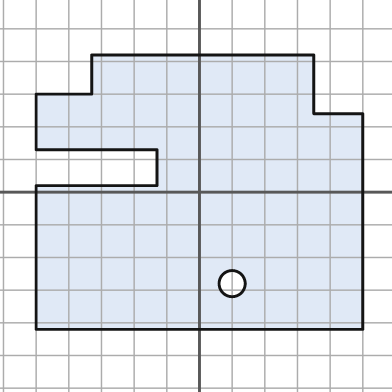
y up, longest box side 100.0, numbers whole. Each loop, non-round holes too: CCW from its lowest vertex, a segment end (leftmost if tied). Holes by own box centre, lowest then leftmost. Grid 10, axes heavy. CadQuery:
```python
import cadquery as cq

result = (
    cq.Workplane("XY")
    .moveTo(-50.0, -42.0)
    .lineTo(50.0, -42.0)
    .lineTo(50.0, 24.0)
    .lineTo(35.0, 24.0)
    .lineTo(35.0, 42.0)
    .lineTo(-33.0, 42.0)
    .lineTo(-33.0, 30.0)
    .lineTo(-50.0, 30.0)
    .lineTo(-50.0, 13.0)
    .lineTo(-13.0, 13.0)
    .lineTo(-13.0, 2.0)
    .lineTo(-50.0, 2.0)
    .close()
    .moveTo(10.0, -28.0)
    .circle(4.0)
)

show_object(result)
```